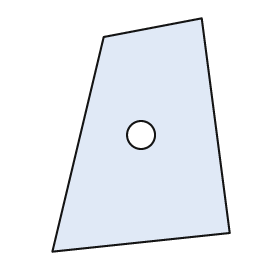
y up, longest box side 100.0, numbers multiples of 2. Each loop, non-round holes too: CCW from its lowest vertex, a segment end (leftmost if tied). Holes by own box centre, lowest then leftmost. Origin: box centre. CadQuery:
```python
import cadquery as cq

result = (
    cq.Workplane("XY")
    .moveTo(-38.0, -50.0)
    .lineTo(38.0, -42.0)
    .lineTo(26.0, 50.0)
    .lineTo(-16.0, 42.0)
    .close()
    .moveTo(0.0, 0.0)
    .circle(6.0)
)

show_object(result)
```